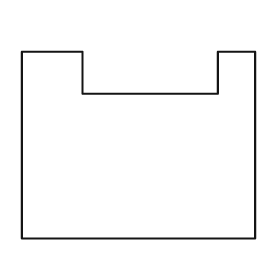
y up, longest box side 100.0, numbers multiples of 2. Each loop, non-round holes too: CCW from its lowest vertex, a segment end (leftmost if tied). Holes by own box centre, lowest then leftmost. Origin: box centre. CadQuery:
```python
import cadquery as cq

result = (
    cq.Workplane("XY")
    .moveTo(-50.0, -40.0)
    .lineTo(50.0, -40.0)
    .lineTo(50.0, 40.0)
    .lineTo(34.0, 40.0)
    .lineTo(34.0, 22.0)
    .lineTo(-24.0, 22.0)
    .lineTo(-24.0, 40.0)
    .lineTo(-50.0, 40.0)
    .close()
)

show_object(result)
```